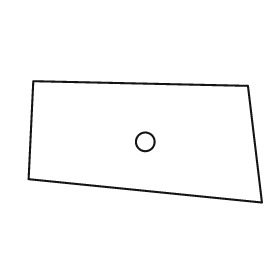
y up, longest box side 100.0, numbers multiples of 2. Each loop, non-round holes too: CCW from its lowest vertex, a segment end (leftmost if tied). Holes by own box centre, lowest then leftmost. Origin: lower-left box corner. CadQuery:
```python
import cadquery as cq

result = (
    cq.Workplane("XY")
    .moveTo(100.0, 0.0)
    .lineTo(94.0, 50.0)
    .lineTo(2.0, 52.0)
    .lineTo(0.0, 10.0)
    .close()
    .moveTo(50.0, 26.0)
    .circle(4.0)
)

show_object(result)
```